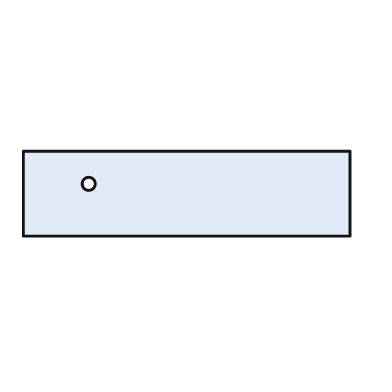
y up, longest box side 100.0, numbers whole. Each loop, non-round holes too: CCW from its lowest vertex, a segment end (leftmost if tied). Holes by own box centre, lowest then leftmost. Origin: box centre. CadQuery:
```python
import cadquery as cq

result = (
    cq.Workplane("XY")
    .moveTo(-50.0, -13.0)
    .lineTo(50.0, -13.0)
    .lineTo(50.0, 13.0)
    .lineTo(-50.0, 13.0)
    .close()
    .moveTo(-30.0, 3.0)
    .circle(2.0)
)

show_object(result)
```